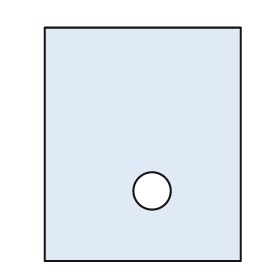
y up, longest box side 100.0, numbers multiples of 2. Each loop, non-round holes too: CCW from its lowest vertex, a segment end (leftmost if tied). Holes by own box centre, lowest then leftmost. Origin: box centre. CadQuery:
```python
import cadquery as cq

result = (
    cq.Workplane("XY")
    .moveTo(-42.0, -50.0)
    .lineTo(42.0, -50.0)
    .lineTo(42.0, 50.0)
    .lineTo(-42.0, 50.0)
    .close()
    .moveTo(4.0, -20.0)
    .circle(8.0)
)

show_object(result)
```